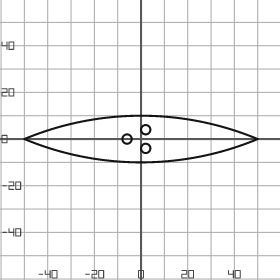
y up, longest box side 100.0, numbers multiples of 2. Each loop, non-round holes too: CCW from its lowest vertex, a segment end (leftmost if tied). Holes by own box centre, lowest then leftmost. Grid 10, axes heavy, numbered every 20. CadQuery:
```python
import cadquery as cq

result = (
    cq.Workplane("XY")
    .moveTo(-50.0, 0.0)
    .threePointArc((0.0, -10.0), (50.0, 0.0))
    .threePointArc((0.0, 10.0), (-50.0, 0.0))
    .close()
    .moveTo(2.0, -4.0)
    .circle(2.0)
    .moveTo(-6.0, 0.0)
    .circle(2.0)
    .moveTo(2.0, 4.0)
    .circle(2.0)
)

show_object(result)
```